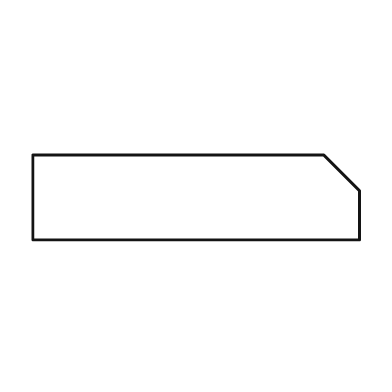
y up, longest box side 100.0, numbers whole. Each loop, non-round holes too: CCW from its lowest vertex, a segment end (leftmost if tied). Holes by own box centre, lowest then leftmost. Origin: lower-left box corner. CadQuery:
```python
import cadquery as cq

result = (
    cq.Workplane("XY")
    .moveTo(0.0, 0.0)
    .lineTo(100.0, 0.0)
    .lineTo(100.0, 15.0)
    .lineTo(89.0, 26.0)
    .lineTo(0.0, 26.0)
    .close()
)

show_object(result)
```